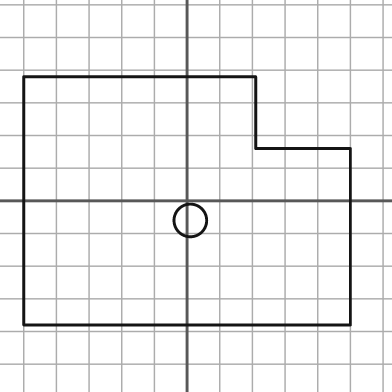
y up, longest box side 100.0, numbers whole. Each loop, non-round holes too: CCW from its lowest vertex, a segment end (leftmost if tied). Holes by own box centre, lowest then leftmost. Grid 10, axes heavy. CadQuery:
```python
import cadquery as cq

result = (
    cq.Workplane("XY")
    .moveTo(-50.0, -38.0)
    .lineTo(50.0, -38.0)
    .lineTo(50.0, 16.0)
    .lineTo(21.0, 16.0)
    .lineTo(21.0, 38.0)
    .lineTo(-50.0, 38.0)
    .close()
    .moveTo(1.0, -6.0)
    .circle(5.0)
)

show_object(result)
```